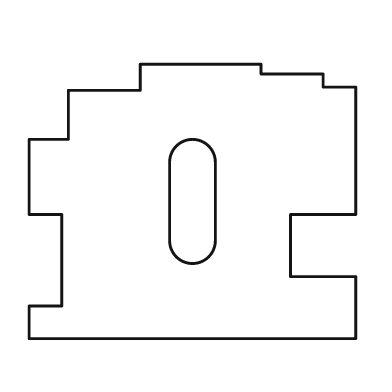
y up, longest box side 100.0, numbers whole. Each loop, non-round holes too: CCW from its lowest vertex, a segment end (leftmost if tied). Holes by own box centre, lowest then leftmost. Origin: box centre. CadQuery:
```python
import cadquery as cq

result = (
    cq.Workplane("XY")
    .moveTo(-50.0, -42.0)
    .lineTo(50.0, -42.0)
    .lineTo(50.0, -23.0)
    .lineTo(30.0, -23.0)
    .lineTo(30.0, -4.0)
    .lineTo(50.0, -4.0)
    .lineTo(50.0, 35.0)
    .lineTo(40.0, 35.0)
    .lineTo(40.0, 39.0)
    .lineTo(21.0, 39.0)
    .lineTo(21.0, 42.0)
    .lineTo(-16.0, 42.0)
    .lineTo(-16.0, 34.0)
    .lineTo(-38.0, 34.0)
    .lineTo(-38.0, 19.0)
    .lineTo(-50.0, 19.0)
    .lineTo(-50.0, -4.0)
    .lineTo(-40.0, -4.0)
    .lineTo(-40.0, -32.0)
    .lineTo(-50.0, -32.0)
    .close()
    .moveTo(-7.0, -12.0)
    .threePointArc((0.0, -19.0), (7.0, -12.0))
    .lineTo(7.0, 12.0)
    .threePointArc((0.0, 19.0), (-7.0, 12.0))
    .close()
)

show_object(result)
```